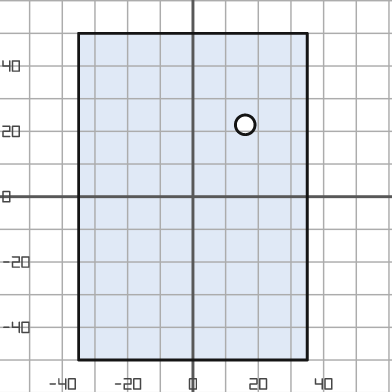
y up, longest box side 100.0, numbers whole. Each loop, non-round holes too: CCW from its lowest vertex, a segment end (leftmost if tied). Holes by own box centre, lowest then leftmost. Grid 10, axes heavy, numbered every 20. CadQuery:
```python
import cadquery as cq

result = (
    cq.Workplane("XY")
    .moveTo(-35.0, -50.0)
    .lineTo(35.0, -50.0)
    .lineTo(35.0, 50.0)
    .lineTo(-35.0, 50.0)
    .close()
    .moveTo(16.0, 22.0)
    .circle(3.0)
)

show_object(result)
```